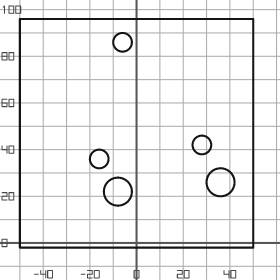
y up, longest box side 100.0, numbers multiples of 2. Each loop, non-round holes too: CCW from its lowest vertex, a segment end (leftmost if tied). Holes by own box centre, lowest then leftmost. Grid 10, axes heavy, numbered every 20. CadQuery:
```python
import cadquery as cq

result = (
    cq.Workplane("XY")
    .moveTo(-50.0, -2.0)
    .lineTo(50.0, -2.0)
    .lineTo(50.0, 96.0)
    .lineTo(-50.0, 96.0)
    .close()
    .moveTo(-8.0, 22.0)
    .circle(6.0)
    .moveTo(36.0, 26.0)
    .circle(6.0)
    .moveTo(-16.0, 36.0)
    .circle(4.0)
    .moveTo(28.0, 42.0)
    .circle(4.0)
    .moveTo(-6.0, 86.0)
    .circle(4.0)
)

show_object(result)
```